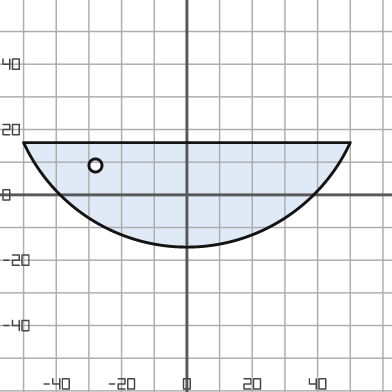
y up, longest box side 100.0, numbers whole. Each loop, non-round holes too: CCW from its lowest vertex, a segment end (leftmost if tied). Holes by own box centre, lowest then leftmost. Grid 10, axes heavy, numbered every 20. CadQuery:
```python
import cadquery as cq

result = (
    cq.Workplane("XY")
    .moveTo(-50.0, 16.0)
    .threePointArc((0.0, -16.0), (50.0, 16.0))
    .close()
    .moveTo(-28.0, 9.0)
    .circle(2.0)
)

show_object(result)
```